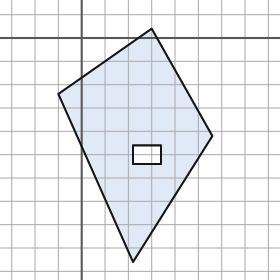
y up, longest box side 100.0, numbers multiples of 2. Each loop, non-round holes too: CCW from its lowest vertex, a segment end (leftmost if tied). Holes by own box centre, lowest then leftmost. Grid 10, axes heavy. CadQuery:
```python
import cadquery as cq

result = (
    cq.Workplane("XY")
    .moveTo(22.0, -96.0)
    .lineTo(56.0, -42.0)
    .lineTo(30.0, 4.0)
    .lineTo(-10.0, -24.0)
    .close()
    .moveTo(22.0, -54.0)
    .lineTo(34.0, -54.0)
    .lineTo(34.0, -46.0)
    .lineTo(22.0, -46.0)
    .close()
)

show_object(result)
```